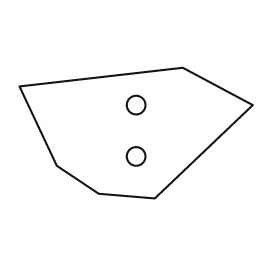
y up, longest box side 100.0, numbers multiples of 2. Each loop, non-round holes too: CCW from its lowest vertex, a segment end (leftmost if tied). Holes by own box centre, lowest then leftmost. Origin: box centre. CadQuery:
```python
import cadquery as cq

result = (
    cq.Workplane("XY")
    .moveTo(8.0, -28.0)
    .lineTo(50.0, 12.0)
    .lineTo(20.0, 28.0)
    .lineTo(-50.0, 20.0)
    .lineTo(-34.0, -14.0)
    .lineTo(-16.0, -26.0)
    .close()
    .moveTo(0.0, -10.0)
    .circle(4.0)
    .moveTo(0.0, 12.0)
    .circle(4.0)
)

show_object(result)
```